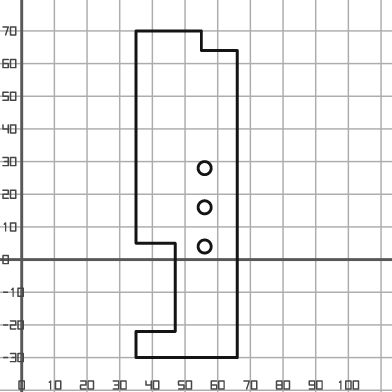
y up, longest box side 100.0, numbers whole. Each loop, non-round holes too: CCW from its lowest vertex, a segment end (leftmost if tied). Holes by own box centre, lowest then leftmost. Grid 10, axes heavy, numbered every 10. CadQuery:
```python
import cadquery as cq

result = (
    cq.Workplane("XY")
    .moveTo(35.0, -30.0)
    .lineTo(66.0, -30.0)
    .lineTo(66.0, 64.0)
    .lineTo(55.0, 64.0)
    .lineTo(55.0, 70.0)
    .lineTo(35.0, 70.0)
    .lineTo(35.0, 5.0)
    .lineTo(47.0, 5.0)
    .lineTo(47.0, -22.0)
    .lineTo(35.0, -22.0)
    .close()
    .moveTo(56.0, 4.0)
    .circle(2.0)
    .moveTo(56.0, 16.0)
    .circle(2.0)
    .moveTo(56.0, 28.0)
    .circle(2.0)
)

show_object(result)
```